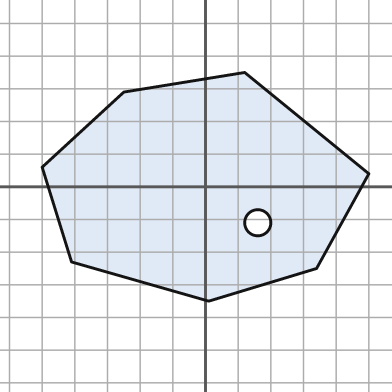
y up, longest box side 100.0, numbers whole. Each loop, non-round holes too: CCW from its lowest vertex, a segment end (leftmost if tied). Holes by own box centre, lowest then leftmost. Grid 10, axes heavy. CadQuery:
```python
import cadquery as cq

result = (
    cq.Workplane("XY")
    .moveTo(1.0, -35.0)
    .lineTo(34.0, -25.0)
    .lineTo(50.0, 4.0)
    .lineTo(12.0, 35.0)
    .lineTo(-25.0, 29.0)
    .lineTo(-50.0, 6.0)
    .lineTo(-41.0, -23.0)
    .close()
    .moveTo(16.0, -11.0)
    .circle(4.0)
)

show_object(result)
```